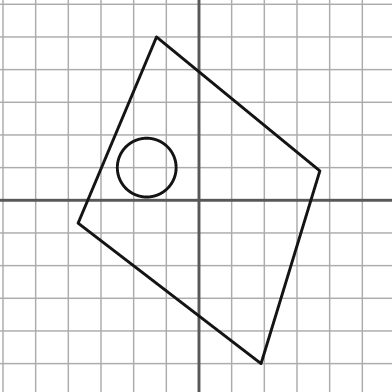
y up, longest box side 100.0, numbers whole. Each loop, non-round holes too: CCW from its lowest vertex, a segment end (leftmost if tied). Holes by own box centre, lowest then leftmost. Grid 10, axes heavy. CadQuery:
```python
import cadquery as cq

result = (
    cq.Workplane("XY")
    .moveTo(19.0, -50.0)
    .lineTo(37.0, 9.0)
    .lineTo(-13.0, 50.0)
    .lineTo(-37.0, -7.0)
    .close()
    .moveTo(-16.0, 10.0)
    .circle(9.0)
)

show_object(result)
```